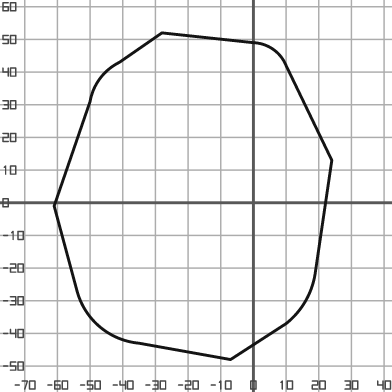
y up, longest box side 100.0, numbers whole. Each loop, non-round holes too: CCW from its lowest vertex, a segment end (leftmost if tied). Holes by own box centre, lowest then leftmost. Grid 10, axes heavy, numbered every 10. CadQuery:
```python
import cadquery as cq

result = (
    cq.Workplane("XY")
    .moveTo(-7.0, -48.0)
    .lineTo(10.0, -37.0)
    .threePointArc((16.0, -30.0), (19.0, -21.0))
    .lineTo(24.0, 13.0)
    .lineTo(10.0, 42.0)
    .threePointArc((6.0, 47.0), (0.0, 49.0))
    .lineTo(-28.0, 52.0)
    .lineTo(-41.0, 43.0)
    .threePointArc((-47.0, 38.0), (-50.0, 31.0))
    .lineTo(-61.0, -1.0)
    .lineTo(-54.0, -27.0)
    .threePointArc((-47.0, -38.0), (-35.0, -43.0))
    .close()
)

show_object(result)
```